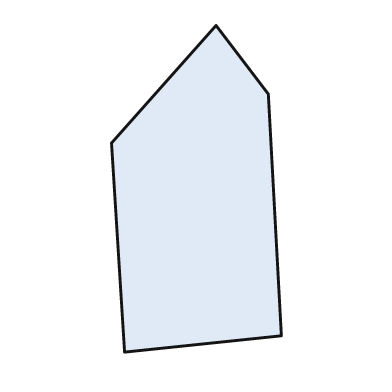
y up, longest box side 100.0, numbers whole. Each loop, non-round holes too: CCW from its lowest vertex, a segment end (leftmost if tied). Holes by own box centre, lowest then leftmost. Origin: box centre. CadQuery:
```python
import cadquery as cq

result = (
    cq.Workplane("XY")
    .moveTo(-22.0, -50.0)
    .lineTo(26.0, -45.0)
    .lineTo(22.0, 29.0)
    .lineTo(6.0, 50.0)
    .lineTo(-26.0, 14.0)
    .close()
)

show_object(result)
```